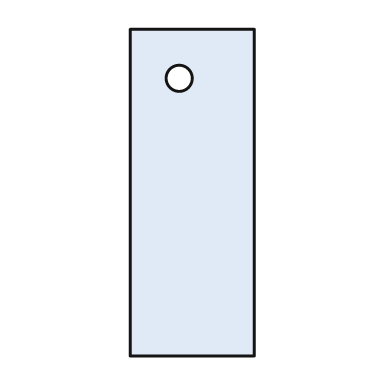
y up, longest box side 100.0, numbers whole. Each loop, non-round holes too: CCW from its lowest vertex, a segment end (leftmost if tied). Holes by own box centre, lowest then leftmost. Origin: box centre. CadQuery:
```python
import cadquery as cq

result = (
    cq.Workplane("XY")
    .moveTo(-19.0, -50.0)
    .lineTo(19.0, -50.0)
    .lineTo(19.0, 50.0)
    .lineTo(-19.0, 50.0)
    .close()
    .moveTo(-4.0, 35.0)
    .circle(4.0)
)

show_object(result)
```